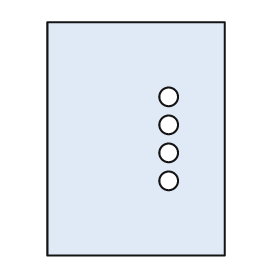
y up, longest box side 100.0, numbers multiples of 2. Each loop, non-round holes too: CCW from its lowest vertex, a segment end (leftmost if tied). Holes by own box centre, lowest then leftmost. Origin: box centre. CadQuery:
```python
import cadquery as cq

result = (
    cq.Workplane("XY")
    .moveTo(-38.0, -50.0)
    .lineTo(38.0, -50.0)
    .lineTo(38.0, 50.0)
    .lineTo(-38.0, 50.0)
    .close()
    .moveTo(14.0, -18.0)
    .circle(4.0)
    .moveTo(14.0, -6.0)
    .circle(4.0)
    .moveTo(14.0, 6.0)
    .circle(4.0)
    .moveTo(14.0, 18.0)
    .circle(4.0)
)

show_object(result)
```